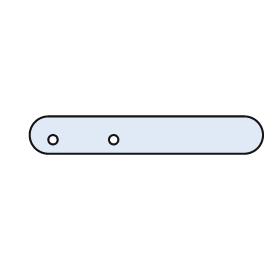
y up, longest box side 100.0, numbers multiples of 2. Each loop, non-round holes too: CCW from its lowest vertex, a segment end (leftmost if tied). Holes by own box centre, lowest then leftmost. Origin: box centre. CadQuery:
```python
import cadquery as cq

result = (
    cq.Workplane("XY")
    .moveTo(-42.0, -8.0)
    .lineTo(42.0, -8.0)
    .threePointArc((50.0, 0.0), (42.0, 8.0))
    .lineTo(-42.0, 8.0)
    .threePointArc((-50.0, 0.0), (-42.0, -8.0))
    .close()
    .moveTo(-40.0, -2.0)
    .circle(2.0)
    .moveTo(-14.0, -2.0)
    .circle(2.0)
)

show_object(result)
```